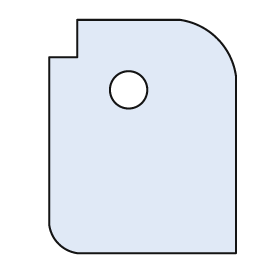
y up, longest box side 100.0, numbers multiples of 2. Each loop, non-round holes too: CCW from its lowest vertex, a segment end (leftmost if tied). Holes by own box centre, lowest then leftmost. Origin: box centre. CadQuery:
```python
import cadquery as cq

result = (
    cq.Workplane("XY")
    .moveTo(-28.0, -50.0)
    .lineTo(40.0, -50.0)
    .lineTo(40.0, 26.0)
    .threePointArc((32.0, 42.0), (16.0, 50.0))
    .lineTo(-28.0, 50.0)
    .lineTo(-28.0, 34.0)
    .lineTo(-40.0, 34.0)
    .lineTo(-40.0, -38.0)
    .threePointArc((-36.0, -46.0), (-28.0, -50.0))
    .close()
    .moveTo(-6.0, 20.0)
    .circle(8.0)
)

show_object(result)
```